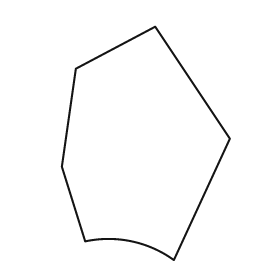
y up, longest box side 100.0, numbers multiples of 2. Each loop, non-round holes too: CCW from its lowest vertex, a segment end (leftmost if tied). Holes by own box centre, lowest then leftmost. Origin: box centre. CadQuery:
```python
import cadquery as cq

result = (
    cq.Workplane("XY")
    .moveTo(12.0, -50.0)
    .lineTo(36.0, 2.0)
    .lineTo(4.0, 50.0)
    .lineTo(-30.0, 32.0)
    .lineTo(-36.0, -10.0)
    .lineTo(-26.0, -42.0)
    .threePointArc((-6.0, -42.0), (12.0, -50.0))
    .close()
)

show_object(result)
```